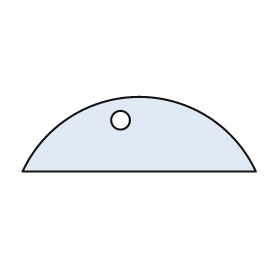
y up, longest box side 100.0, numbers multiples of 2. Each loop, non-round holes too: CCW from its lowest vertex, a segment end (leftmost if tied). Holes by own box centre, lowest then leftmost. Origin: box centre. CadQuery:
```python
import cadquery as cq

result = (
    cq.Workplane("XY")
    .moveTo(-50.0, -16.0)
    .lineTo(50.0, -16.0)
    .threePointArc((0.0, 16.0), (-50.0, -16.0))
    .close()
    .moveTo(-8.0, 6.0)
    .circle(4.0)
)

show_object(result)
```